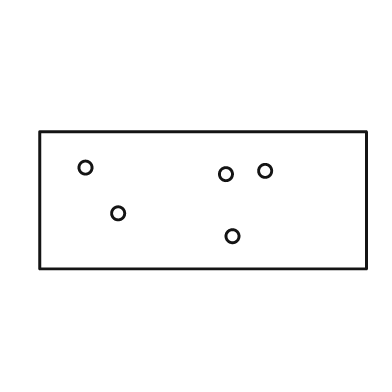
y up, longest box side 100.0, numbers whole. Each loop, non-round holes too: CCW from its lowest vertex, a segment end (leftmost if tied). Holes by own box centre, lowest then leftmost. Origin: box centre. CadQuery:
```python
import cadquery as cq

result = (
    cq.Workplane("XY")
    .moveTo(-50.0, -21.0)
    .lineTo(50.0, -21.0)
    .lineTo(50.0, 21.0)
    .lineTo(-50.0, 21.0)
    .close()
    .moveTo(9.0, -11.0)
    .circle(2.0)
    .moveTo(-26.0, -4.0)
    .circle(2.0)
    .moveTo(7.0, 8.0)
    .circle(2.0)
    .moveTo(19.0, 9.0)
    .circle(2.0)
    .moveTo(-36.0, 10.0)
    .circle(2.0)
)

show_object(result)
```